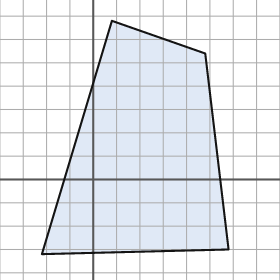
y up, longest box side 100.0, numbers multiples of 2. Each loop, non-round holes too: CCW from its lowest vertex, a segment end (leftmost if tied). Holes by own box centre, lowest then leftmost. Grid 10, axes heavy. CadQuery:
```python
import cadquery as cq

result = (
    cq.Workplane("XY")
    .moveTo(-22.0, -32.0)
    .lineTo(58.0, -30.0)
    .lineTo(48.0, 54.0)
    .lineTo(8.0, 68.0)
    .close()
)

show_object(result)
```